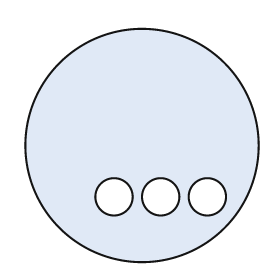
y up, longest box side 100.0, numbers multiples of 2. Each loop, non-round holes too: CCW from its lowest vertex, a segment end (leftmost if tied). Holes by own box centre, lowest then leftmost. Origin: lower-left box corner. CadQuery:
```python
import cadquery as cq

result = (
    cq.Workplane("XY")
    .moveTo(50.0, 50.0)
    .circle(50.0)
    .moveTo(38.0, 28.0)
    .circle(8.0)
    .moveTo(58.0, 28.0)
    .circle(8.0)
    .moveTo(78.0, 28.0)
    .circle(8.0)
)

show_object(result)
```